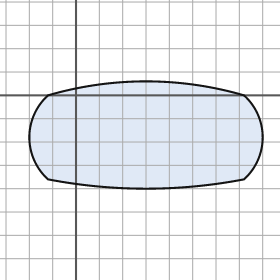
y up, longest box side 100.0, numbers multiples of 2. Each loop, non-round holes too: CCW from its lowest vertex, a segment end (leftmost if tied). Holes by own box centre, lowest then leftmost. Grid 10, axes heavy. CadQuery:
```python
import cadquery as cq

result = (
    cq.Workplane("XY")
    .moveTo(-12.0, -36.0)
    .threePointArc((30.0, -40.0), (72.0, -36.0))
    .threePointArc((80.0, -18.0), (72.0, 0.0))
    .threePointArc((30.0, 6.0), (-12.0, 0.0))
    .threePointArc((-20.0, -18.0), (-12.0, -36.0))
    .close()
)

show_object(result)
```